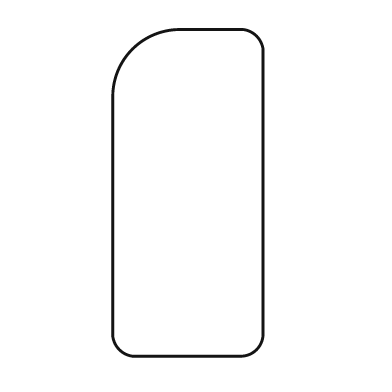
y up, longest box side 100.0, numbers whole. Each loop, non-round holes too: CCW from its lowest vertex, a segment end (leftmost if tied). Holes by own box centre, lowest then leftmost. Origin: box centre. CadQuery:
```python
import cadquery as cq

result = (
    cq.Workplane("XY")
    .moveTo(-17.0, -50.0)
    .lineTo(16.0, -50.0)
    .threePointArc((21.0, -48.0), (23.0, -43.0))
    .lineTo(23.0, 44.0)
    .threePointArc((21.0, 48.0), (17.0, 50.0))
    .lineTo(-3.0, 50.0)
    .threePointArc((-17.0, 44.0), (-23.0, 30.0))
    .lineTo(-23.0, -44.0)
    .threePointArc((-21.0, -48.0), (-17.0, -50.0))
    .close()
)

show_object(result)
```